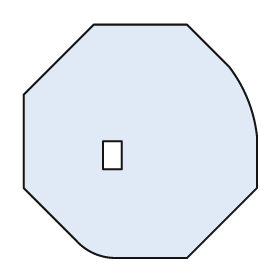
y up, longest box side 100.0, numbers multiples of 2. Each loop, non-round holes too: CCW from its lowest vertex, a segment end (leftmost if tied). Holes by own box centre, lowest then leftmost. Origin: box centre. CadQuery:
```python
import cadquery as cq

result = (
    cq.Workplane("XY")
    .moveTo(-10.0, -50.0)
    .lineTo(20.0, -50.0)
    .lineTo(50.0, -20.0)
    .lineTo(50.0, 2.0)
    .threePointArc((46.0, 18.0), (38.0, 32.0))
    .lineTo(20.0, 50.0)
    .lineTo(-20.0, 50.0)
    .lineTo(-50.0, 20.0)
    .lineTo(-50.0, -20.0)
    .lineTo(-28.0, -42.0)
    .threePointArc((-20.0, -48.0), (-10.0, -50.0))
    .close()
    .moveTo(-16.0, -12.0)
    .lineTo(-8.0, -12.0)
    .lineTo(-8.0, 0.0)
    .lineTo(-16.0, 0.0)
    .close()
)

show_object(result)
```